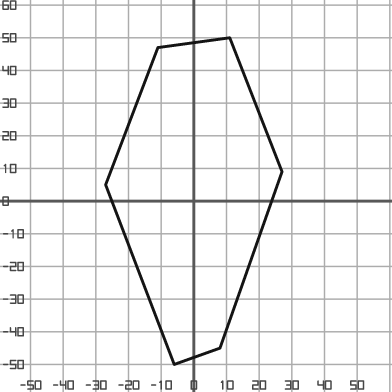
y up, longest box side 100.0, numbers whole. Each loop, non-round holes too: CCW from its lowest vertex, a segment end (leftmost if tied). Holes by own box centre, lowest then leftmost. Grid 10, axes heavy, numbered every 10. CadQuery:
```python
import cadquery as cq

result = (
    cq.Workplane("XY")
    .moveTo(-6.0, -50.0)
    .lineTo(8.0, -45.0)
    .lineTo(27.0, 9.0)
    .lineTo(11.0, 50.0)
    .lineTo(-11.0, 47.0)
    .lineTo(-27.0, 5.0)
    .close()
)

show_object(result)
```